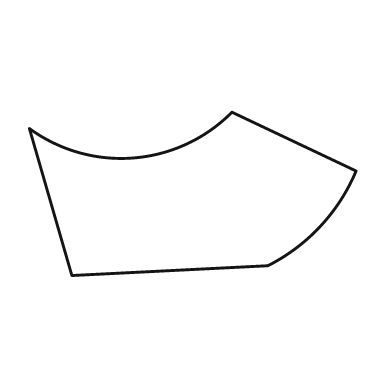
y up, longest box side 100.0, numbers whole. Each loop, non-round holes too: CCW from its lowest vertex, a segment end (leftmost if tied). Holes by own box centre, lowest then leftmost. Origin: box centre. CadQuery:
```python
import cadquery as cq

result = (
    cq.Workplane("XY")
    .moveTo(-37.0, -25.0)
    .lineTo(23.0, -22.0)
    .threePointArc((39.0, -10.0), (50.0, 7.0))
    .lineTo(12.0, 25.0)
    .threePointArc((-18.0, 11.0), (-50.0, 20.0))
    .close()
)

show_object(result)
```